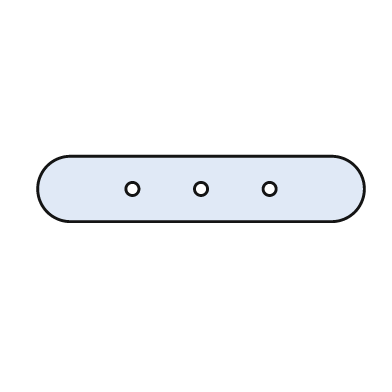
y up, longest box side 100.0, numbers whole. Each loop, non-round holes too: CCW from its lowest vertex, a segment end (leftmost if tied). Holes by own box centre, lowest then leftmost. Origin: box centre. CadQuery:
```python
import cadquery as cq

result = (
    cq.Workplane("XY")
    .moveTo(-40.0, -10.0)
    .lineTo(40.0, -10.0)
    .threePointArc((50.0, 0.0), (40.0, 10.0))
    .lineTo(-40.0, 10.0)
    .threePointArc((-50.0, 0.0), (-40.0, -10.0))
    .close()
    .moveTo(-21.0, 0.0)
    .circle(2.0)
    .moveTo(0.0, 0.0)
    .circle(2.0)
    .moveTo(21.0, 0.0)
    .circle(2.0)
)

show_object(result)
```